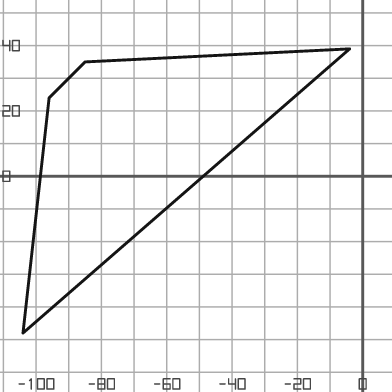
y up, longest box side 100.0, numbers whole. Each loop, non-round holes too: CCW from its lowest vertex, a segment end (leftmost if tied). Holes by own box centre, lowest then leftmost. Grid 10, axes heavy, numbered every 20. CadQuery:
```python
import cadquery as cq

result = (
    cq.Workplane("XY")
    .moveTo(-104.0, -48.0)
    .lineTo(-4.0, 39.0)
    .lineTo(-85.0, 35.0)
    .lineTo(-96.0, 24.0)
    .close()
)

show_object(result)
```